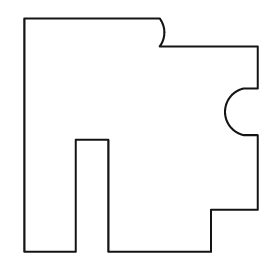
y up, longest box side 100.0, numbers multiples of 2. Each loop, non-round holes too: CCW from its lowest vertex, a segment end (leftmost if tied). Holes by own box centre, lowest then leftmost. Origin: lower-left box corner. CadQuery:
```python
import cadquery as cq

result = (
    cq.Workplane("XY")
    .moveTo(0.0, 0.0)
    .lineTo(22.0, 0.0)
    .lineTo(22.0, 48.0)
    .lineTo(36.0, 48.0)
    .lineTo(36.0, 0.0)
    .lineTo(80.0, 0.0)
    .lineTo(80.0, 18.0)
    .lineTo(100.0, 18.0)
    .lineTo(100.0, 50.0)
    .lineTo(94.0, 50.0)
    .threePointArc((86.0, 60.0), (94.0, 70.0))
    .lineTo(100.0, 70.0)
    .lineTo(100.0, 88.0)
    .lineTo(58.0, 88.0)
    .threePointArc((60.0, 94.0), (58.0, 100.0))
    .lineTo(0.0, 100.0)
    .close()
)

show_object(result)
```